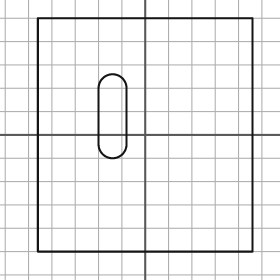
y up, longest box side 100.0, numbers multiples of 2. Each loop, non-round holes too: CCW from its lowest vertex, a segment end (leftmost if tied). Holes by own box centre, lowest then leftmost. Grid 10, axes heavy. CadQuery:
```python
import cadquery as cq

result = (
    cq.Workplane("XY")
    .moveTo(-46.0, -50.0)
    .lineTo(46.0, -50.0)
    .lineTo(46.0, 50.0)
    .lineTo(-46.0, 50.0)
    .close()
    .moveTo(-20.0, -4.0)
    .threePointArc((-14.0, -10.0), (-8.0, -4.0))
    .lineTo(-8.0, 20.0)
    .threePointArc((-14.0, 26.0), (-20.0, 20.0))
    .close()
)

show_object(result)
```